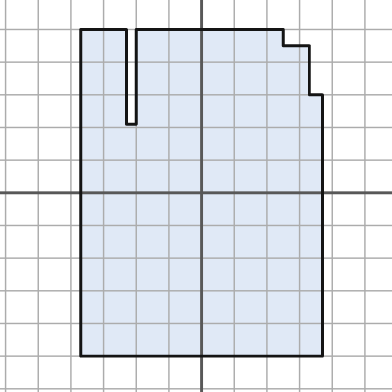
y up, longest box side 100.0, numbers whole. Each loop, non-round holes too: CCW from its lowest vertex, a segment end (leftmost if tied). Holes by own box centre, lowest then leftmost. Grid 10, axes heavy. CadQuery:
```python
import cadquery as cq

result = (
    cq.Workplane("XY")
    .moveTo(-37.0, -50.0)
    .lineTo(37.0, -50.0)
    .lineTo(37.0, 30.0)
    .lineTo(33.0, 30.0)
    .lineTo(33.0, 45.0)
    .lineTo(25.0, 45.0)
    .lineTo(25.0, 50.0)
    .lineTo(-20.0, 50.0)
    .lineTo(-20.0, 21.0)
    .lineTo(-23.0, 21.0)
    .lineTo(-23.0, 50.0)
    .lineTo(-37.0, 50.0)
    .close()
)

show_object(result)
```